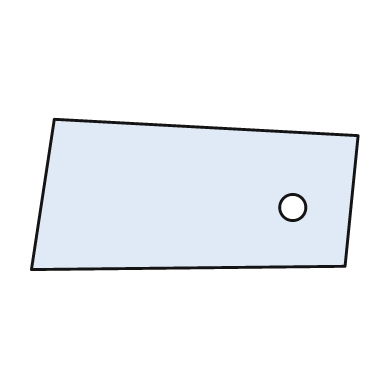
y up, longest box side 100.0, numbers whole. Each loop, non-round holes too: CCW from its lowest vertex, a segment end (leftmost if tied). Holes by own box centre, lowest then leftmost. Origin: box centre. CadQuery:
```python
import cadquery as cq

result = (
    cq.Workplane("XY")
    .moveTo(-50.0, -23.0)
    .lineTo(46.0, -22.0)
    .lineTo(50.0, 18.0)
    .lineTo(-43.0, 23.0)
    .close()
    .moveTo(30.0, -4.0)
    .circle(4.0)
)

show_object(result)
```